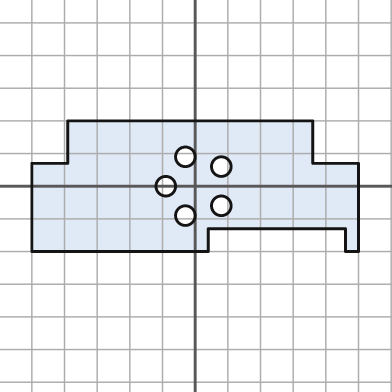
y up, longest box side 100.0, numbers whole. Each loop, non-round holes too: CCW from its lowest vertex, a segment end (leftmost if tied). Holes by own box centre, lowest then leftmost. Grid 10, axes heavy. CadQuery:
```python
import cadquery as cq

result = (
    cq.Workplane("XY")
    .moveTo(-50.0, -20.0)
    .lineTo(4.0, -20.0)
    .lineTo(4.0, -13.0)
    .lineTo(46.0, -13.0)
    .lineTo(46.0, -20.0)
    .lineTo(50.0, -20.0)
    .lineTo(50.0, 7.0)
    .lineTo(36.0, 7.0)
    .lineTo(36.0, 20.0)
    .lineTo(-39.0, 20.0)
    .lineTo(-39.0, 7.0)
    .lineTo(-50.0, 7.0)
    .close()
    .moveTo(-3.0, -9.0)
    .circle(3.0)
    .moveTo(8.0, -6.0)
    .circle(3.0)
    .moveTo(-9.0, 0.0)
    .circle(3.0)
    .moveTo(8.0, 6.0)
    .circle(3.0)
    .moveTo(-3.0, 9.0)
    .circle(3.0)
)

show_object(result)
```